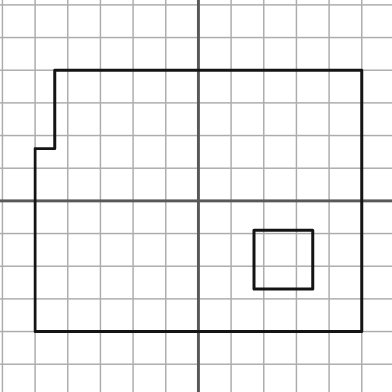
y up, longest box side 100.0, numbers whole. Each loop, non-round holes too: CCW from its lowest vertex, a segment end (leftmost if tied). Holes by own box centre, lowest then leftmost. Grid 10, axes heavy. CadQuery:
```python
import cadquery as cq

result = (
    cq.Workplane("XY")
    .moveTo(-50.0, -40.0)
    .lineTo(50.0, -40.0)
    .lineTo(50.0, 40.0)
    .lineTo(-44.0, 40.0)
    .lineTo(-44.0, 16.0)
    .lineTo(-50.0, 16.0)
    .close()
    .moveTo(17.0, -27.0)
    .lineTo(35.0, -27.0)
    .lineTo(35.0, -9.0)
    .lineTo(17.0, -9.0)
    .close()
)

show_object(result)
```